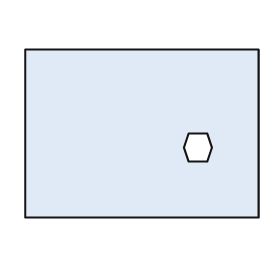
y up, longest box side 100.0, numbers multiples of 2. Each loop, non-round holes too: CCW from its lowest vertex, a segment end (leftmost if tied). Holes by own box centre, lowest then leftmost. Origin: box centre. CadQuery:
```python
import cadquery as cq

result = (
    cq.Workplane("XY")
    .moveTo(-50.0, -36.0)
    .lineTo(50.0, -36.0)
    .lineTo(50.0, 36.0)
    .lineTo(-50.0, 36.0)
    .close()
    .moveTo(20.0, -12.0)
    .lineTo(28.0, -12.0)
    .lineTo(30.0, -6.0)
    .lineTo(28.0, 0.0)
    .lineTo(20.0, 0.0)
    .lineTo(18.0, -6.0)
    .close()
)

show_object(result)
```